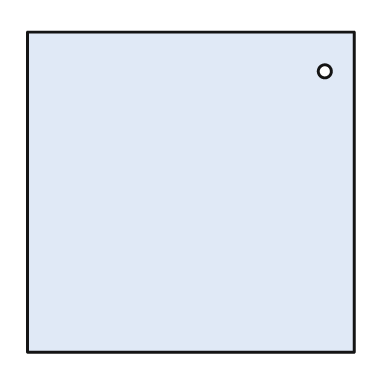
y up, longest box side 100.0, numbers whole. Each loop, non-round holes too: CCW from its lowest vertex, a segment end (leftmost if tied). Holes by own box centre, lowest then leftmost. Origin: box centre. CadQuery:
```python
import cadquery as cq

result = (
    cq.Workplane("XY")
    .moveTo(-50.0, -49.0)
    .lineTo(50.0, -49.0)
    .lineTo(50.0, 49.0)
    .lineTo(-50.0, 49.0)
    .close()
    .moveTo(41.0, 37.0)
    .circle(2.0)
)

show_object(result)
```